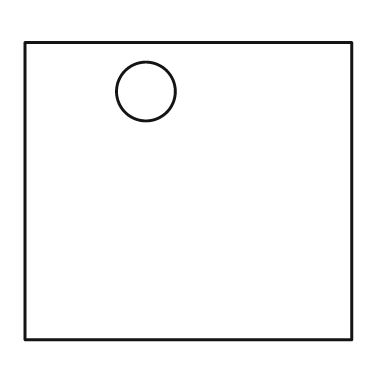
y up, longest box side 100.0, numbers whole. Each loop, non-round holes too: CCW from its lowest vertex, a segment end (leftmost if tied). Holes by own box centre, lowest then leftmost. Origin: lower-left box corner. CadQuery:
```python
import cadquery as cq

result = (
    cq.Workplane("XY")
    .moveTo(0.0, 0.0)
    .lineTo(100.0, 0.0)
    .lineTo(100.0, 91.0)
    .lineTo(0.0, 91.0)
    .close()
    .moveTo(37.0, 76.0)
    .circle(9.0)
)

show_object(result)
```